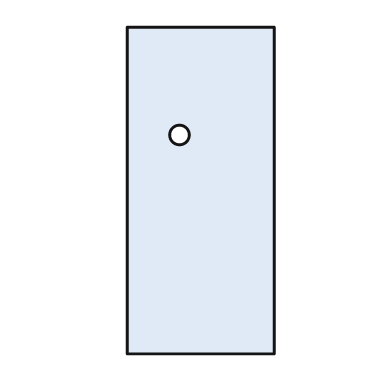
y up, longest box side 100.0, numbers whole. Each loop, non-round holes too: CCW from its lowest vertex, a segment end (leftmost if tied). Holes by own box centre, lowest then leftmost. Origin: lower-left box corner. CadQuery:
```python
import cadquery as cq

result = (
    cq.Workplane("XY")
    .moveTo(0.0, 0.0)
    .lineTo(45.0, 0.0)
    .lineTo(45.0, 100.0)
    .lineTo(0.0, 100.0)
    .close()
    .moveTo(16.0, 67.0)
    .circle(3.0)
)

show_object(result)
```